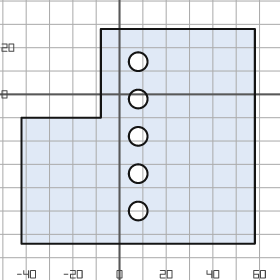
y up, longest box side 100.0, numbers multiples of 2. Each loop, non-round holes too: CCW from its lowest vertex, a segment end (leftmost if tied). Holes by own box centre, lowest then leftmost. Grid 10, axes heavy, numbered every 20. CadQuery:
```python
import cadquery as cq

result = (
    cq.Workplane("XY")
    .moveTo(-42.0, -64.0)
    .lineTo(58.0, -64.0)
    .lineTo(58.0, 28.0)
    .lineTo(-8.0, 28.0)
    .lineTo(-8.0, -10.0)
    .lineTo(-42.0, -10.0)
    .close()
    .moveTo(8.0, -50.0)
    .circle(4.0)
    .moveTo(8.0, -34.0)
    .circle(4.0)
    .moveTo(8.0, -18.0)
    .circle(4.0)
    .moveTo(8.0, -2.0)
    .circle(4.0)
    .moveTo(8.0, 14.0)
    .circle(4.0)
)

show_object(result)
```